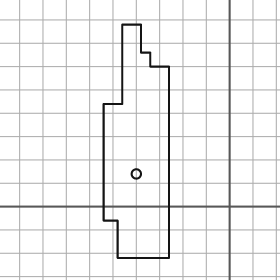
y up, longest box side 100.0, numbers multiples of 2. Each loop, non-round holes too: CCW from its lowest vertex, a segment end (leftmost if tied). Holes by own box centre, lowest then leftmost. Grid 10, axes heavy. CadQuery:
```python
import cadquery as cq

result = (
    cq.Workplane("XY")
    .moveTo(-48.0, -22.0)
    .lineTo(-26.0, -22.0)
    .lineTo(-26.0, 60.0)
    .lineTo(-34.0, 60.0)
    .lineTo(-34.0, 66.0)
    .lineTo(-38.0, 66.0)
    .lineTo(-38.0, 78.0)
    .lineTo(-46.0, 78.0)
    .lineTo(-46.0, 44.0)
    .lineTo(-54.0, 44.0)
    .lineTo(-54.0, -6.0)
    .lineTo(-48.0, -6.0)
    .close()
    .moveTo(-40.0, 14.0)
    .circle(2.0)
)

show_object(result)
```